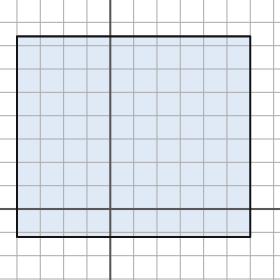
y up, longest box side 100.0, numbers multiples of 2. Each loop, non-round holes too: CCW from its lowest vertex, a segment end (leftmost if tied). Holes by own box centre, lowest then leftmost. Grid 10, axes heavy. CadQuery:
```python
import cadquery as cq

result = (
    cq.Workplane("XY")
    .moveTo(-40.0, -12.0)
    .lineTo(60.0, -12.0)
    .lineTo(60.0, 74.0)
    .lineTo(-40.0, 74.0)
    .close()
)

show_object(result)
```